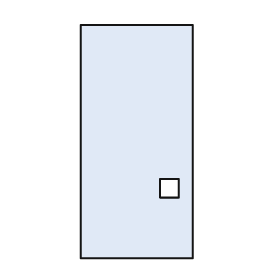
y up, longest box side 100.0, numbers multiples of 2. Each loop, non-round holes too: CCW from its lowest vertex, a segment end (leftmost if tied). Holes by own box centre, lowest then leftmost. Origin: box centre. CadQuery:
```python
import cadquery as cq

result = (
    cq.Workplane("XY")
    .moveTo(-24.0, -50.0)
    .lineTo(24.0, -50.0)
    .lineTo(24.0, 50.0)
    .lineTo(-24.0, 50.0)
    .close()
    .moveTo(10.0, -24.0)
    .lineTo(18.0, -24.0)
    .lineTo(18.0, -16.0)
    .lineTo(10.0, -16.0)
    .close()
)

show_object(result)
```